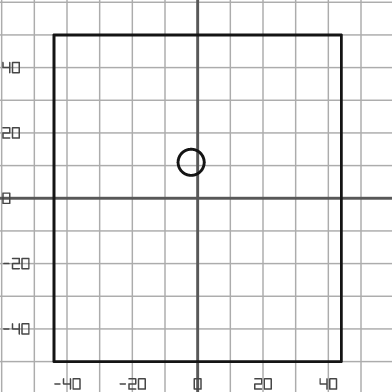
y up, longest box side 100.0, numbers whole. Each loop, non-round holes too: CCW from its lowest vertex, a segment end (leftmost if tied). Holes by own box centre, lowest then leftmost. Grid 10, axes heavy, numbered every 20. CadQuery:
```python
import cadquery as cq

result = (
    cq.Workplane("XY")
    .moveTo(-44.0, -50.0)
    .lineTo(44.0, -50.0)
    .lineTo(44.0, 50.0)
    .lineTo(-44.0, 50.0)
    .close()
    .moveTo(-2.0, 11.0)
    .circle(4.0)
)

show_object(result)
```